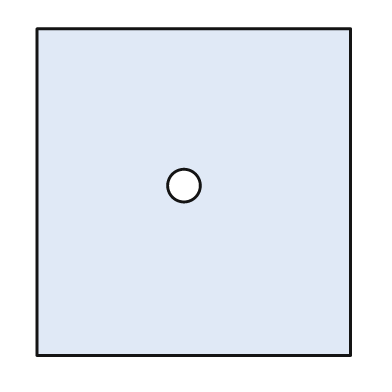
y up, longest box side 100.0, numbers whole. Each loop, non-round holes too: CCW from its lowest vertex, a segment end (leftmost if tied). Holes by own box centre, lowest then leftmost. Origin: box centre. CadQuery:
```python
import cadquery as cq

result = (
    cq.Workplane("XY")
    .moveTo(-48.0, -50.0)
    .lineTo(48.0, -50.0)
    .lineTo(48.0, 50.0)
    .lineTo(-48.0, 50.0)
    .close()
    .moveTo(-3.0, 2.0)
    .circle(5.0)
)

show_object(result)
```